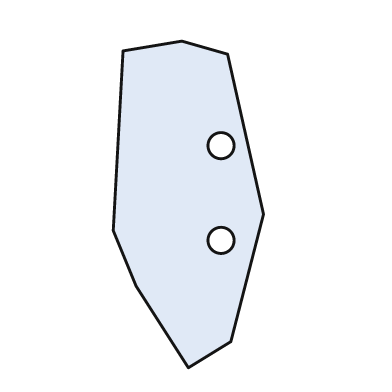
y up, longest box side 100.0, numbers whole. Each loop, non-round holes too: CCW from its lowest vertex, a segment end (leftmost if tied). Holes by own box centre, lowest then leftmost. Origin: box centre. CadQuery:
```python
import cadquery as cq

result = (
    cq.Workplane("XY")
    .moveTo(0.0, -50.0)
    .lineTo(13.0, -42.0)
    .lineTo(23.0, -3.0)
    .lineTo(12.0, 46.0)
    .lineTo(-2.0, 50.0)
    .lineTo(-20.0, 47.0)
    .lineTo(-23.0, -8.0)
    .lineTo(-16.0, -25.0)
    .close()
    .moveTo(10.0, -11.0)
    .circle(4.0)
    .moveTo(10.0, 18.0)
    .circle(4.0)
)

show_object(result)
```